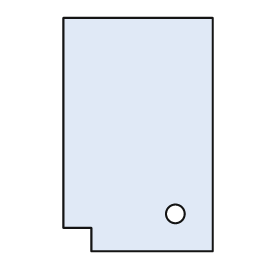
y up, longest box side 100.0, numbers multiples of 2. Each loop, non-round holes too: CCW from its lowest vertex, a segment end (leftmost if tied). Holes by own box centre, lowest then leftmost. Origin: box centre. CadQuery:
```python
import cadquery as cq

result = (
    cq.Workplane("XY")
    .moveTo(-20.0, -50.0)
    .lineTo(32.0, -50.0)
    .lineTo(32.0, 50.0)
    .lineTo(-32.0, 50.0)
    .lineTo(-32.0, -40.0)
    .lineTo(-20.0, -40.0)
    .close()
    .moveTo(16.0, -34.0)
    .circle(4.0)
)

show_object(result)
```